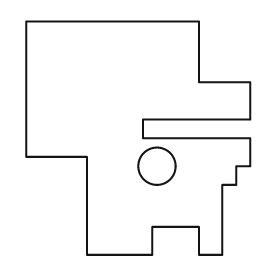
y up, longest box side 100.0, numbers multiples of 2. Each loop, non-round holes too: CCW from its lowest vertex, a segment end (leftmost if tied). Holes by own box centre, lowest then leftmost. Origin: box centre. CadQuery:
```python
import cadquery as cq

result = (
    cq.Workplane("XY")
    .moveTo(-22.0, -50.0)
    .lineTo(6.0, -50.0)
    .lineTo(6.0, -38.0)
    .lineTo(26.0, -38.0)
    .lineTo(26.0, -50.0)
    .lineTo(36.0, -50.0)
    .lineTo(36.0, -20.0)
    .lineTo(42.0, -20.0)
    .lineTo(42.0, -12.0)
    .lineTo(48.0, -12.0)
    .lineTo(48.0, 0.0)
    .lineTo(2.0, 0.0)
    .lineTo(2.0, 8.0)
    .lineTo(48.0, 8.0)
    .lineTo(48.0, 24.0)
    .lineTo(26.0, 24.0)
    .lineTo(26.0, 50.0)
    .lineTo(-48.0, 50.0)
    .lineTo(-48.0, -8.0)
    .lineTo(-22.0, -8.0)
    .close()
    .moveTo(8.0, -12.0)
    .circle(8.0)
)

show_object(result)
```